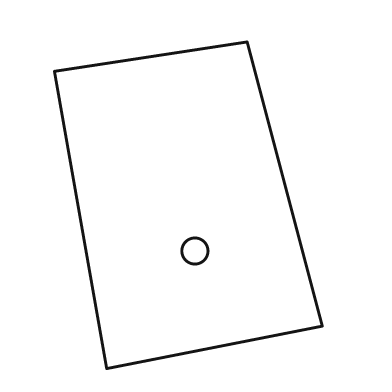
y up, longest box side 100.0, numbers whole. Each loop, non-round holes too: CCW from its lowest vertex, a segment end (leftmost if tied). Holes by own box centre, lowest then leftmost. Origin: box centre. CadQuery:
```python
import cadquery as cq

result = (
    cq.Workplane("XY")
    .moveTo(-25.0, -50.0)
    .lineTo(41.0, -37.0)
    .lineTo(18.0, 50.0)
    .lineTo(-41.0, 41.0)
    .close()
    .moveTo(2.0, -14.0)
    .circle(4.0)
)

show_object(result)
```